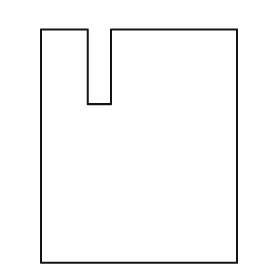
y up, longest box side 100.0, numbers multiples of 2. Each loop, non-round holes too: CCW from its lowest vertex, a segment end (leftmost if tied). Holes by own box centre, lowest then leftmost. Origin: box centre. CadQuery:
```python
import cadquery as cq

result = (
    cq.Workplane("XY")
    .moveTo(-42.0, -50.0)
    .lineTo(42.0, -50.0)
    .lineTo(42.0, 50.0)
    .lineTo(-12.0, 50.0)
    .lineTo(-12.0, 18.0)
    .lineTo(-22.0, 18.0)
    .lineTo(-22.0, 50.0)
    .lineTo(-42.0, 50.0)
    .close()
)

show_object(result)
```